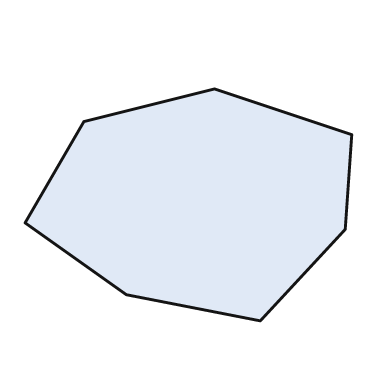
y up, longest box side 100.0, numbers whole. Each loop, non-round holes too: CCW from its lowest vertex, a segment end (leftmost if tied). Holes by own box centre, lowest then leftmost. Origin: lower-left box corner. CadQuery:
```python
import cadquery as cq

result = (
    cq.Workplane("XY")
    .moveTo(72.0, 0.0)
    .lineTo(98.0, 28.0)
    .lineTo(100.0, 57.0)
    .lineTo(58.0, 71.0)
    .lineTo(18.0, 61.0)
    .lineTo(0.0, 30.0)
    .lineTo(31.0, 8.0)
    .close()
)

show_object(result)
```